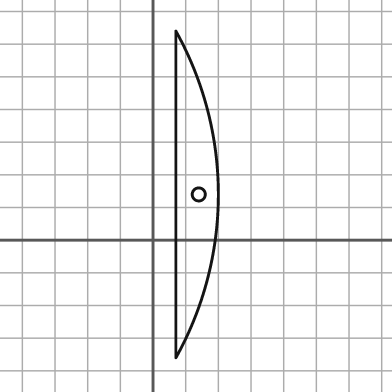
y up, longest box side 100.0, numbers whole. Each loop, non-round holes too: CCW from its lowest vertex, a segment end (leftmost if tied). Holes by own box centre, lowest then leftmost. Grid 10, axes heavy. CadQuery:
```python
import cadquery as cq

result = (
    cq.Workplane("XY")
    .moveTo(7.0, -36.0)
    .threePointArc((20.0, 14.0), (7.0, 64.0))
    .close()
    .moveTo(14.0, 14.0)
    .circle(2.0)
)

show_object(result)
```